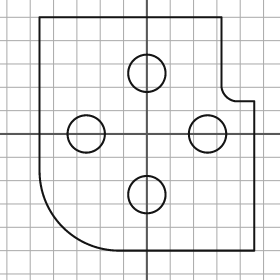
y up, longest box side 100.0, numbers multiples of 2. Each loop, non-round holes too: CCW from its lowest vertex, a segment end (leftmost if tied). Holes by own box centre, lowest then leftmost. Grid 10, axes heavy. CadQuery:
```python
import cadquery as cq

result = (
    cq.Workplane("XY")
    .moveTo(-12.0, -50.0)
    .lineTo(46.0, -50.0)
    .lineTo(46.0, 14.0)
    .lineTo(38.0, 14.0)
    .threePointArc((34.0, 16.0), (32.0, 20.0))
    .lineTo(32.0, 50.0)
    .lineTo(-46.0, 50.0)
    .lineTo(-46.0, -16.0)
    .threePointArc((-36.0, -40.0), (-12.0, -50.0))
    .close()
    .moveTo(0.0, -26.0)
    .circle(8.0)
    .moveTo(-26.0, 0.0)
    .circle(8.0)
    .moveTo(26.0, 0.0)
    .circle(8.0)
    .moveTo(0.0, 26.0)
    .circle(8.0)
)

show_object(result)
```